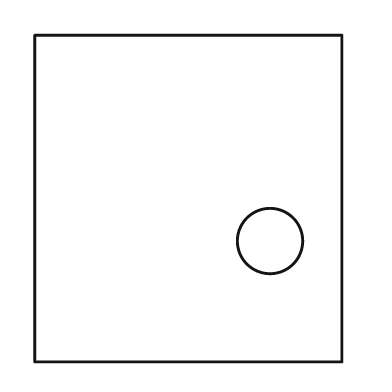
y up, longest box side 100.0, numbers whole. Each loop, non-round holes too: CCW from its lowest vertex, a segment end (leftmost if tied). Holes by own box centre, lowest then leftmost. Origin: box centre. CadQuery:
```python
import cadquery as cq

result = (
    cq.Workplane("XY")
    .moveTo(-47.0, -50.0)
    .lineTo(47.0, -50.0)
    .lineTo(47.0, 50.0)
    .lineTo(-47.0, 50.0)
    .close()
    .moveTo(25.0, -13.0)
    .circle(10.0)
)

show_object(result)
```